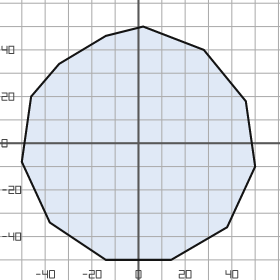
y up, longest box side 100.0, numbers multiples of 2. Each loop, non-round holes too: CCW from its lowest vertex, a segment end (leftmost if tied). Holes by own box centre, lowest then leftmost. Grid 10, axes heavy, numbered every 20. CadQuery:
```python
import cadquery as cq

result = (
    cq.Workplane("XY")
    .moveTo(-14.0, -50.0)
    .lineTo(14.0, -50.0)
    .lineTo(38.0, -36.0)
    .lineTo(50.0, -10.0)
    .lineTo(46.0, 18.0)
    .lineTo(28.0, 40.0)
    .lineTo(2.0, 50.0)
    .lineTo(-14.0, 46.0)
    .lineTo(-34.0, 34.0)
    .lineTo(-46.0, 20.0)
    .lineTo(-50.0, -8.0)
    .lineTo(-38.0, -34.0)
    .close()
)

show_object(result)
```